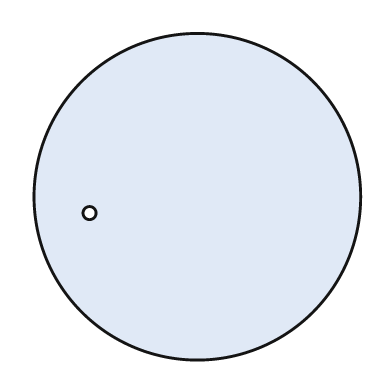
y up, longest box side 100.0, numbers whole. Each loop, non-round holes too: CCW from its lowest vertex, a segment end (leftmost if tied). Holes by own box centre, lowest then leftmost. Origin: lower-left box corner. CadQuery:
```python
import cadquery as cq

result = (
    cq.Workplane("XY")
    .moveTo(50.0, 50.0)
    .circle(50.0)
    .moveTo(17.0, 45.0)
    .circle(2.0)
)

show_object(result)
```